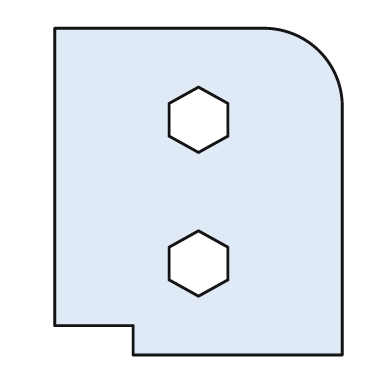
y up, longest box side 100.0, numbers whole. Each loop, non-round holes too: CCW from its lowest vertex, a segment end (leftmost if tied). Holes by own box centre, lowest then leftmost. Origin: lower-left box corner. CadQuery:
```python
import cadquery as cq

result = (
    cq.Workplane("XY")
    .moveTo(24.0, 0.0)
    .lineTo(88.0, 0.0)
    .lineTo(88.0, 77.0)
    .threePointArc((81.0, 93.0), (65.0, 100.0))
    .lineTo(0.0, 100.0)
    .lineTo(0.0, 9.0)
    .lineTo(24.0, 9.0)
    .close()
    .moveTo(44.0, 18.0)
    .lineTo(53.0, 23.0)
    .lineTo(53.0, 33.0)
    .lineTo(44.0, 38.0)
    .lineTo(35.0, 33.0)
    .lineTo(35.0, 23.0)
    .close()
    .moveTo(44.0, 62.0)
    .lineTo(53.0, 67.0)
    .lineTo(53.0, 77.0)
    .lineTo(44.0, 82.0)
    .lineTo(35.0, 77.0)
    .lineTo(35.0, 67.0)
    .close()
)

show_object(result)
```